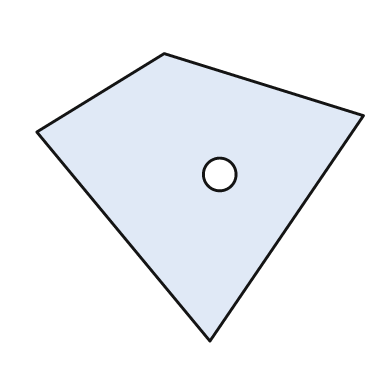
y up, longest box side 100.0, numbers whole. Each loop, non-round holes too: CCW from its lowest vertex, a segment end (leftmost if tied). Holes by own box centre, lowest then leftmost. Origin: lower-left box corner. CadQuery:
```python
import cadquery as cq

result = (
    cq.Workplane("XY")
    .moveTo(53.0, 0.0)
    .lineTo(100.0, 69.0)
    .lineTo(39.0, 88.0)
    .lineTo(0.0, 64.0)
    .close()
    .moveTo(56.0, 51.0)
    .circle(5.0)
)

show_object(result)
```